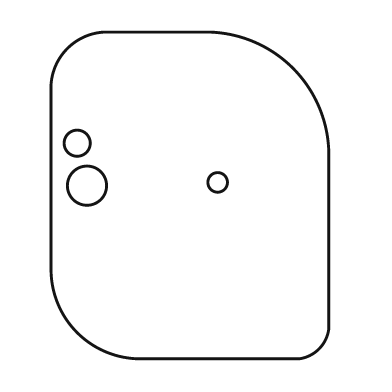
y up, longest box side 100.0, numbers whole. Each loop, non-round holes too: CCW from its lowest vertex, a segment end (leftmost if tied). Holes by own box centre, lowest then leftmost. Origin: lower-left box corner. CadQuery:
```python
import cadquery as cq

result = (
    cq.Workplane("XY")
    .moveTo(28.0, 0.0)
    .lineTo(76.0, 0.0)
    .threePointArc((82.0, 3.0), (85.0, 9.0))
    .lineTo(85.0, 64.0)
    .threePointArc((74.0, 89.0), (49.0, 100.0))
    .lineTo(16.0, 100.0)
    .threePointArc((5.0, 95.0), (0.0, 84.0))
    .lineTo(0.0, 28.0)
    .threePointArc((8.0, 8.0), (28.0, 0.0))
    .close()
    .moveTo(11.0, 53.0)
    .circle(6.0)
    .moveTo(51.0, 54.0)
    .circle(3.0)
    .moveTo(8.0, 66.0)
    .circle(4.0)
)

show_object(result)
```